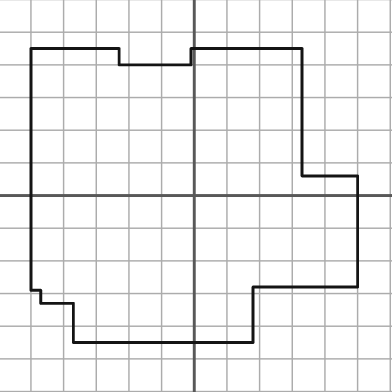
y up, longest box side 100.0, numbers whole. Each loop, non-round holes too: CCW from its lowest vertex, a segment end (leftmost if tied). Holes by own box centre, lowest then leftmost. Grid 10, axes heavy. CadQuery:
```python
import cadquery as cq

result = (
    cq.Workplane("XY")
    .moveTo(-37.0, -45.0)
    .lineTo(18.0, -45.0)
    .lineTo(18.0, -28.0)
    .lineTo(50.0, -28.0)
    .lineTo(50.0, 6.0)
    .lineTo(33.0, 6.0)
    .lineTo(33.0, 45.0)
    .lineTo(-1.0, 45.0)
    .lineTo(-1.0, 40.0)
    .lineTo(-23.0, 40.0)
    .lineTo(-23.0, 45.0)
    .lineTo(-50.0, 45.0)
    .lineTo(-50.0, -29.0)
    .lineTo(-47.0, -29.0)
    .lineTo(-47.0, -33.0)
    .lineTo(-37.0, -33.0)
    .close()
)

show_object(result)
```